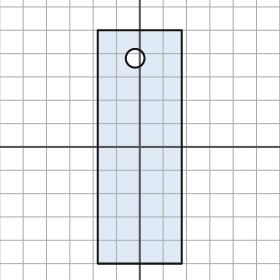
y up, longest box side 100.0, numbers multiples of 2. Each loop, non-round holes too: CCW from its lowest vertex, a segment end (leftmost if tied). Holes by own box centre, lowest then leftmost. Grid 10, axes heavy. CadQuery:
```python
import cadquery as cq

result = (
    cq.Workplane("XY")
    .moveTo(-18.0, -50.0)
    .lineTo(18.0, -50.0)
    .lineTo(18.0, 50.0)
    .lineTo(-18.0, 50.0)
    .close()
    .moveTo(-2.0, 38.0)
    .circle(4.0)
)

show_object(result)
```